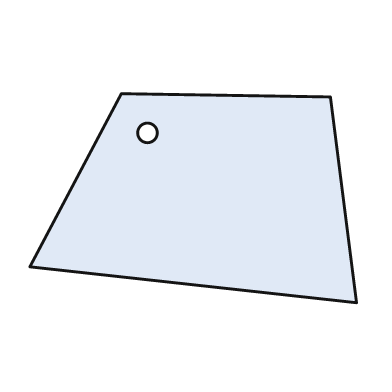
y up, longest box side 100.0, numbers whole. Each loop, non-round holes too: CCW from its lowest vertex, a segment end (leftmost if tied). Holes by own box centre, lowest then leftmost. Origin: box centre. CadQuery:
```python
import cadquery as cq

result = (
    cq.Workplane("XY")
    .moveTo(50.0, -32.0)
    .lineTo(42.0, 31.0)
    .lineTo(-22.0, 32.0)
    .lineTo(-50.0, -21.0)
    .close()
    .moveTo(-14.0, 20.0)
    .circle(3.0)
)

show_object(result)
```